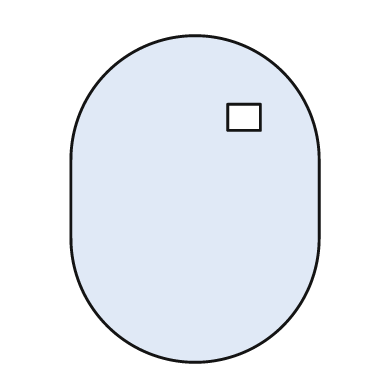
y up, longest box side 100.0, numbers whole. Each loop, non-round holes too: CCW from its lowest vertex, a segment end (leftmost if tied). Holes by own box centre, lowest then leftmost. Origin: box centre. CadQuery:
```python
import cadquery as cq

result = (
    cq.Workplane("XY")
    .moveTo(-38.0, -12.0)
    .threePointArc((0.0, -50.0), (38.0, -12.0))
    .lineTo(38.0, 12.0)
    .threePointArc((0.0, 50.0), (-38.0, 12.0))
    .close()
    .moveTo(10.0, 21.0)
    .lineTo(20.0, 21.0)
    .lineTo(20.0, 29.0)
    .lineTo(10.0, 29.0)
    .close()
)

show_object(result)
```